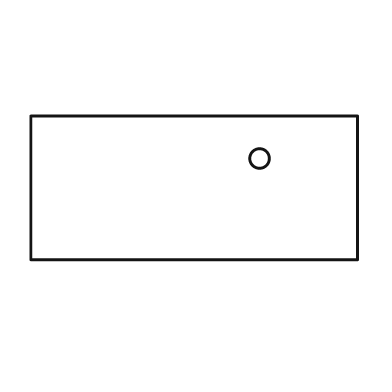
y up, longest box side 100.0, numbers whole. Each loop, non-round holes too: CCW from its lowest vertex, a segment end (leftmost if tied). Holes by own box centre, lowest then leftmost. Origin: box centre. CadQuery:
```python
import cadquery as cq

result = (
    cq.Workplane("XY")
    .moveTo(-50.0, -22.0)
    .lineTo(50.0, -22.0)
    .lineTo(50.0, 22.0)
    .lineTo(-50.0, 22.0)
    .close()
    .moveTo(20.0, 9.0)
    .circle(3.0)
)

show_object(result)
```